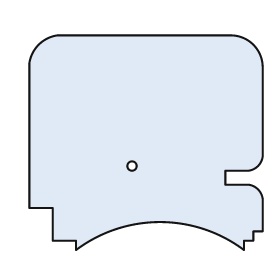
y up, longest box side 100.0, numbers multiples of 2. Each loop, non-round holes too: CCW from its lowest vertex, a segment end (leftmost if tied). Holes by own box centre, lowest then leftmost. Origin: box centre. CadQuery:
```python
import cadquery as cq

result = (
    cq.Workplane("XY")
    .moveTo(-30.0, -46.0)
    .threePointArc((6.0, -34.0), (42.0, -46.0))
    .lineTo(42.0, -42.0)
    .lineTo(46.0, -42.0)
    .lineTo(46.0, -38.0)
    .lineTo(50.0, -38.0)
    .lineTo(50.0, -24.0)
    .threePointArc((48.0, -20.0), (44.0, -18.0))
    .lineTo(34.0, -18.0)
    .lineTo(34.0, -12.0)
    .lineTo(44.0, -12.0)
    .threePointArc((48.0, -10.0), (50.0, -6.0))
    .lineTo(50.0, 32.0)
    .threePointArc((46.0, 42.0), (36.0, 46.0))
    .lineTo(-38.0, 46.0)
    .threePointArc((-46.0, 42.0), (-50.0, 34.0))
    .lineTo(-50.0, -28.0)
    .lineTo(-40.0, -28.0)
    .lineTo(-40.0, -42.0)
    .lineTo(-30.0, -42.0)
    .close()
    .moveTo(-6.0, -10.0)
    .circle(2.0)
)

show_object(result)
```